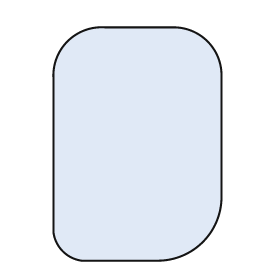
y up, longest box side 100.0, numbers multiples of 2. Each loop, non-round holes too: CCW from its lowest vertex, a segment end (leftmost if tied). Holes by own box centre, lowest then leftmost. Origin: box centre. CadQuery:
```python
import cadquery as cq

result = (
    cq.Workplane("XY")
    .moveTo(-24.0, -50.0)
    .lineTo(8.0, -50.0)
    .threePointArc((28.0, -42.0), (36.0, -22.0))
    .lineTo(36.0, 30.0)
    .threePointArc((30.0, 44.0), (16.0, 50.0))
    .lineTo(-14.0, 50.0)
    .threePointArc((-30.0, 44.0), (-36.0, 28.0))
    .lineTo(-36.0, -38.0)
    .threePointArc((-32.0, -46.0), (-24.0, -50.0))
    .close()
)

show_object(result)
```